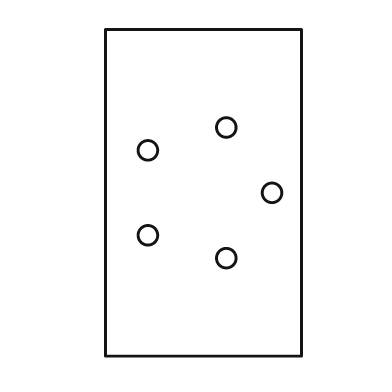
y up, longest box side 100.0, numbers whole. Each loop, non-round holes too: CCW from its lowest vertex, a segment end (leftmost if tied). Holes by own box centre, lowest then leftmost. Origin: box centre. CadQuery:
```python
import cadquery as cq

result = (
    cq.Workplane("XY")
    .moveTo(-30.0, -50.0)
    .lineTo(30.0, -50.0)
    .lineTo(30.0, 50.0)
    .lineTo(-30.0, 50.0)
    .close()
    .moveTo(7.0, -20.0)
    .circle(3.0)
    .moveTo(-17.0, -13.0)
    .circle(3.0)
    .moveTo(21.0, 0.0)
    .circle(3.0)
    .moveTo(-17.0, 13.0)
    .circle(3.0)
    .moveTo(7.0, 20.0)
    .circle(3.0)
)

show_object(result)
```